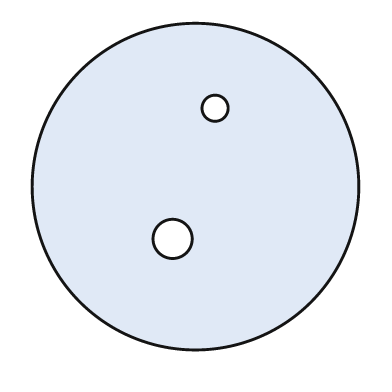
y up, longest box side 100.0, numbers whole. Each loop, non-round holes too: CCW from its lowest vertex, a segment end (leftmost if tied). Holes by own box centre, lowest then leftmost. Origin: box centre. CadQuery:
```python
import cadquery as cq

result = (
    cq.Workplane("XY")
    .moveTo(0.0, 0.0)
    .circle(50.0)
    .moveTo(-7.0, -16.0)
    .circle(6.0)
    .moveTo(6.0, 24.0)
    .circle(4.0)
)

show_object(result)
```